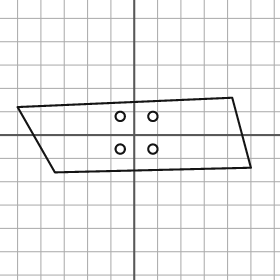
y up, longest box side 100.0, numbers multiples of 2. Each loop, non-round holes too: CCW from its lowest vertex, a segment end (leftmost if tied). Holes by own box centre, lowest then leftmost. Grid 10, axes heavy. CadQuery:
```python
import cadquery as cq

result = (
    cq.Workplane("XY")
    .moveTo(-34.0, -16.0)
    .lineTo(50.0, -14.0)
    .lineTo(42.0, 16.0)
    .lineTo(-50.0, 12.0)
    .close()
    .moveTo(-6.0, -6.0)
    .circle(2.0)
    .moveTo(8.0, -6.0)
    .circle(2.0)
    .moveTo(-6.0, 8.0)
    .circle(2.0)
    .moveTo(8.0, 8.0)
    .circle(2.0)
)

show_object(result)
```